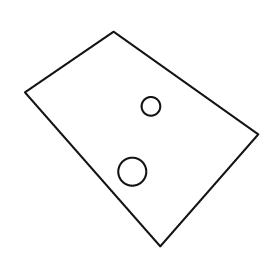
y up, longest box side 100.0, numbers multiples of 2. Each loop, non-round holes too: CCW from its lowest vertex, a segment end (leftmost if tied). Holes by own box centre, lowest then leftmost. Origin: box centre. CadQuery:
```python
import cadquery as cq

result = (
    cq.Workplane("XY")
    .moveTo(8.0, -46.0)
    .lineTo(50.0, 2.0)
    .lineTo(-12.0, 46.0)
    .lineTo(-50.0, 20.0)
    .close()
    .moveTo(-4.0, -14.0)
    .circle(6.0)
    .moveTo(4.0, 14.0)
    .circle(4.0)
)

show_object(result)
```